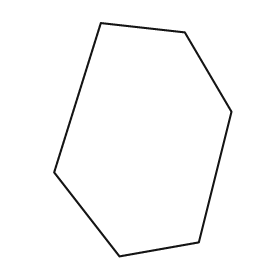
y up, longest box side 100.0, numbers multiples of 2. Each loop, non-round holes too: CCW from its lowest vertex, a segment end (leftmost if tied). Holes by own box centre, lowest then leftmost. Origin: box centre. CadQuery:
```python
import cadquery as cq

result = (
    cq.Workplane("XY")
    .moveTo(-10.0, -50.0)
    .lineTo(24.0, -44.0)
    .lineTo(38.0, 12.0)
    .lineTo(18.0, 46.0)
    .lineTo(-18.0, 50.0)
    .lineTo(-38.0, -14.0)
    .close()
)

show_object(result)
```